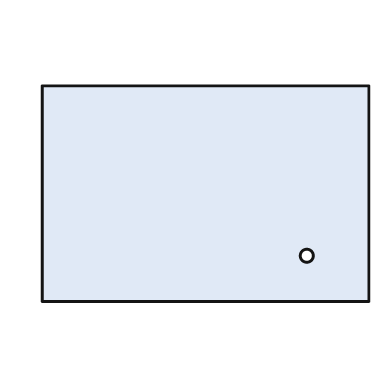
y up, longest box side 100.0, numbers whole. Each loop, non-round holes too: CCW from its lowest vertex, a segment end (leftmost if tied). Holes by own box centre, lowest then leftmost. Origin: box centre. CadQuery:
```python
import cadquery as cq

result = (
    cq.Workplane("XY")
    .moveTo(-50.0, -33.0)
    .lineTo(50.0, -33.0)
    .lineTo(50.0, 33.0)
    .lineTo(-50.0, 33.0)
    .close()
    .moveTo(31.0, -19.0)
    .circle(2.0)
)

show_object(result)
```